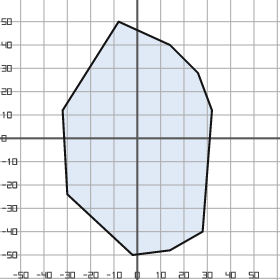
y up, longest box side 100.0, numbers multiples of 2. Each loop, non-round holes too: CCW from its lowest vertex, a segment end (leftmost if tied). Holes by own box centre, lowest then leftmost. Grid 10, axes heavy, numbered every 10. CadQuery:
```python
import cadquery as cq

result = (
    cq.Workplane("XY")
    .moveTo(-2.0, -50.0)
    .lineTo(14.0, -48.0)
    .lineTo(28.0, -40.0)
    .lineTo(32.0, 12.0)
    .lineTo(26.0, 28.0)
    .lineTo(14.0, 40.0)
    .lineTo(-8.0, 50.0)
    .lineTo(-32.0, 12.0)
    .lineTo(-30.0, -24.0)
    .close()
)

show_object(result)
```